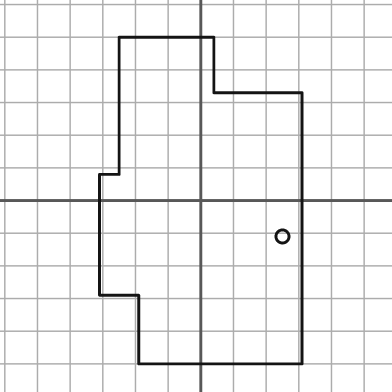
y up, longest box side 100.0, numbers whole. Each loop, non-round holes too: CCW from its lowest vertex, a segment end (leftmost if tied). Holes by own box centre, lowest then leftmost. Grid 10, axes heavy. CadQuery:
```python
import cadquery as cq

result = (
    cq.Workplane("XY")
    .moveTo(-19.0, -50.0)
    .lineTo(31.0, -50.0)
    .lineTo(31.0, 33.0)
    .lineTo(4.0, 33.0)
    .lineTo(4.0, 50.0)
    .lineTo(-25.0, 50.0)
    .lineTo(-25.0, 8.0)
    .lineTo(-31.0, 8.0)
    .lineTo(-31.0, -29.0)
    .lineTo(-19.0, -29.0)
    .close()
    .moveTo(25.0, -11.0)
    .circle(2.0)
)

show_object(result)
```